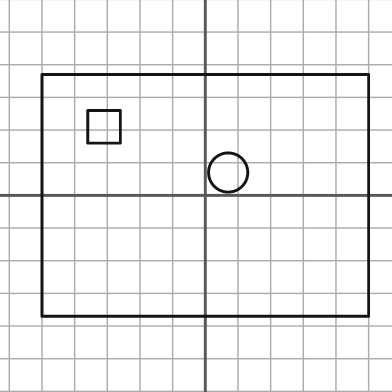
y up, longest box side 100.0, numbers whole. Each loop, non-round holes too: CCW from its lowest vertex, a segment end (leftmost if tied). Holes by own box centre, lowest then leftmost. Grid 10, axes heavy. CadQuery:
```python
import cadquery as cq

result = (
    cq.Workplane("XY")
    .moveTo(-50.0, -37.0)
    .lineTo(50.0, -37.0)
    .lineTo(50.0, 37.0)
    .lineTo(-50.0, 37.0)
    .close()
    .moveTo(7.0, 7.0)
    .circle(6.0)
    .moveTo(-36.0, 16.0)
    .lineTo(-26.0, 16.0)
    .lineTo(-26.0, 26.0)
    .lineTo(-36.0, 26.0)
    .close()
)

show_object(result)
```